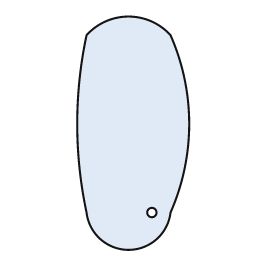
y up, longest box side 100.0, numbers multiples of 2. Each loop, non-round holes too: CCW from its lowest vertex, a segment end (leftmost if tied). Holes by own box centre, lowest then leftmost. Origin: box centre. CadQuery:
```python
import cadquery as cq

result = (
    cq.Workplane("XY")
    .moveTo(-20.0, -34.0)
    .threePointArc((-2.0, -50.0), (16.0, -34.0))
    .threePointArc((24.0, 4.0), (16.0, 42.0))
    .threePointArc((-2.0, 50.0), (-20.0, 42.0))
    .threePointArc((-24.0, 4.0), (-20.0, -34.0))
    .close()
    .moveTo(8.0, -34.0)
    .circle(2.0)
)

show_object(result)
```